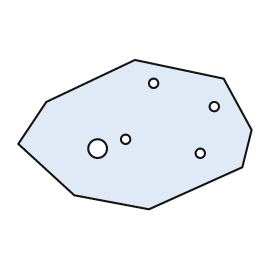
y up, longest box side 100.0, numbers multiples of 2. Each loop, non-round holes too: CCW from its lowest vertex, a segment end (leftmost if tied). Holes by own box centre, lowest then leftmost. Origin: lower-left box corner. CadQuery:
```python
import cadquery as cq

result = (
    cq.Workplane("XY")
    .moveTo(56.0, 0.0)
    .lineTo(96.0, 18.0)
    .lineTo(100.0, 34.0)
    .lineTo(88.0, 56.0)
    .lineTo(50.0, 64.0)
    .lineTo(12.0, 46.0)
    .lineTo(0.0, 28.0)
    .lineTo(24.0, 6.0)
    .close()
    .moveTo(78.0, 24.0)
    .circle(2.0)
    .moveTo(34.0, 26.0)
    .circle(4.0)
    .moveTo(46.0, 30.0)
    .circle(2.0)
    .moveTo(84.0, 44.0)
    .circle(2.0)
    .moveTo(58.0, 54.0)
    .circle(2.0)
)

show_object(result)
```